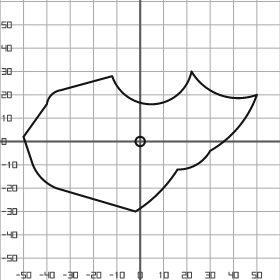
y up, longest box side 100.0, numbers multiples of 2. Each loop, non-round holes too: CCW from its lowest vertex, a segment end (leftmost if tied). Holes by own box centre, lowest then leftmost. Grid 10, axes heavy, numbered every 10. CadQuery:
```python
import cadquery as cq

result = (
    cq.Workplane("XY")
    .moveTo(-2.0, -30.0)
    .threePointArc((8.0, -22.0), (16.0, -12.0))
    .threePointArc((24.0, -10.0), (30.0, -4.0))
    .threePointArc((42.0, 6.0), (50.0, 20.0))
    .threePointArc((34.0, 20.0), (22.0, 30.0))
    .threePointArc((6.0, 16.0), (-12.0, 28.0))
    .lineTo(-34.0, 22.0)
    .threePointArc((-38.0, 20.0), (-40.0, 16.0))
    .lineTo(-50.0, 2.0)
    .lineTo(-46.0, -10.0)
    .threePointArc((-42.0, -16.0), (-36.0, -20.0))
    .close()
    .moveTo(0.0, 0.0)
    .circle(2.0)
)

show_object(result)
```